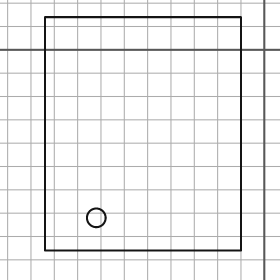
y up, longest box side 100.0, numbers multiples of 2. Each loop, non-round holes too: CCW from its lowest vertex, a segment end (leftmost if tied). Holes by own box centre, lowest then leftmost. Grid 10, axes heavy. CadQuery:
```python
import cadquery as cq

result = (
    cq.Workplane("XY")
    .moveTo(-94.0, -86.0)
    .lineTo(-10.0, -86.0)
    .lineTo(-10.0, 14.0)
    .lineTo(-94.0, 14.0)
    .close()
    .moveTo(-72.0, -72.0)
    .circle(4.0)
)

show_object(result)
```